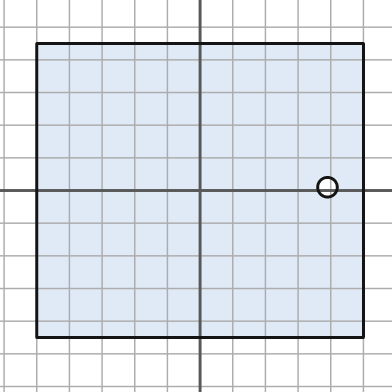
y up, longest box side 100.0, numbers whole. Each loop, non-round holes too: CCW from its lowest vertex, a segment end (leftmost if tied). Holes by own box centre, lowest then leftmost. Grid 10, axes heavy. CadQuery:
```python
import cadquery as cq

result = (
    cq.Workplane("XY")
    .moveTo(-50.0, -45.0)
    .lineTo(50.0, -45.0)
    .lineTo(50.0, 45.0)
    .lineTo(-50.0, 45.0)
    .close()
    .moveTo(39.0, 1.0)
    .circle(3.0)
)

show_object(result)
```